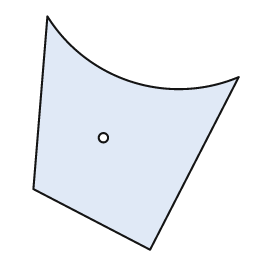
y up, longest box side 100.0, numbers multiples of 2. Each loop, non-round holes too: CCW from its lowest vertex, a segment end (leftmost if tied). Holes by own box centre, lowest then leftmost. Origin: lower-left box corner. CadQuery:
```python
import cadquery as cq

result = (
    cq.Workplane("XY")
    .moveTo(50.0, 0.0)
    .lineTo(88.0, 74.0)
    .threePointArc((42.0, 72.0), (6.0, 100.0))
    .lineTo(0.0, 26.0)
    .close()
    .moveTo(30.0, 48.0)
    .circle(2.0)
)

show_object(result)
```